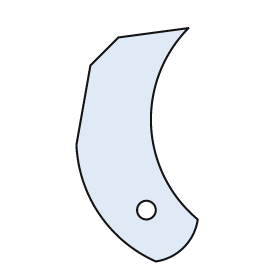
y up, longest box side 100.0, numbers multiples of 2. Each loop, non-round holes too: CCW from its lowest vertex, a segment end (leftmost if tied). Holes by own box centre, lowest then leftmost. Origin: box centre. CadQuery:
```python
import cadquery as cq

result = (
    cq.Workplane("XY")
    .moveTo(8.0, -50.0)
    .threePointArc((20.0, -44.0), (26.0, -32.0))
    .threePointArc((6.0, 8.0), (22.0, 50.0))
    .lineTo(-8.0, 46.0)
    .lineTo(-20.0, 34.0)
    .lineTo(-26.0, 0.0)
    .threePointArc((-16.0, -30.0), (8.0, -50.0))
    .close()
    .moveTo(4.0, -28.0)
    .circle(4.0)
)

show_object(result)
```